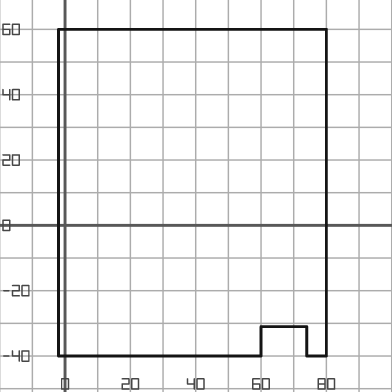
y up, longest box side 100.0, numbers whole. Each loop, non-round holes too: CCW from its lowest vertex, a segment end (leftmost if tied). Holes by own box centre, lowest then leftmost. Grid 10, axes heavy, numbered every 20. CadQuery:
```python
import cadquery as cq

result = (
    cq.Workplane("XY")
    .moveTo(-2.0, -40.0)
    .lineTo(60.0, -40.0)
    .lineTo(60.0, -31.0)
    .lineTo(74.0, -31.0)
    .lineTo(74.0, -40.0)
    .lineTo(80.0, -40.0)
    .lineTo(80.0, 60.0)
    .lineTo(-2.0, 60.0)
    .close()
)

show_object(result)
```